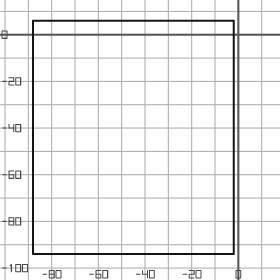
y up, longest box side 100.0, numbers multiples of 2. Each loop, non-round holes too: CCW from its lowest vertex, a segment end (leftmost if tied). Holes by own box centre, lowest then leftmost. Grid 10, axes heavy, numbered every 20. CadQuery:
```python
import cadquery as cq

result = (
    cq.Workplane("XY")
    .moveTo(-88.0, -94.0)
    .lineTo(-2.0, -94.0)
    .lineTo(-2.0, 6.0)
    .lineTo(-88.0, 6.0)
    .close()
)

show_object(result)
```